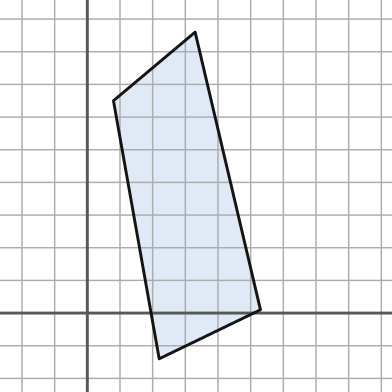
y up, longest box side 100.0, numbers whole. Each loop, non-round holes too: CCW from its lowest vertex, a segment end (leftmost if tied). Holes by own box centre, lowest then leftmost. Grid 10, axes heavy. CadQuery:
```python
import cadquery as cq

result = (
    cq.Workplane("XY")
    .moveTo(22.0, -14.0)
    .lineTo(53.0, 1.0)
    .lineTo(33.0, 86.0)
    .lineTo(8.0, 65.0)
    .close()
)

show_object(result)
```